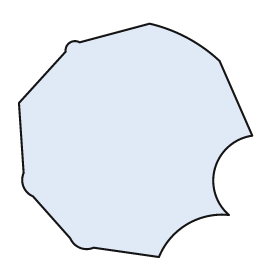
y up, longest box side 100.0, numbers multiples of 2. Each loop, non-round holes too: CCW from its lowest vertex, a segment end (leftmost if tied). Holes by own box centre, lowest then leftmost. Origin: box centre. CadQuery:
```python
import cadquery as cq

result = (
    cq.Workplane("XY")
    .moveTo(10.0, -50.0)
    .threePointArc((22.0, -36.0), (40.0, -32.0))
    .threePointArc((34.0, -12.0), (50.0, 2.0))
    .lineTo(36.0, 34.0)
    .threePointArc((22.0, 44.0), (6.0, 50.0))
    .lineTo(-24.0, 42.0)
    .threePointArc((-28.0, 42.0), (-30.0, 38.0))
    .lineTo(-50.0, 16.0)
    .lineTo(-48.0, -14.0)
    .threePointArc((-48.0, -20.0), (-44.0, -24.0))
    .lineTo(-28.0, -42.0)
    .threePointArc((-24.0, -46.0), (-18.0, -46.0))
    .close()
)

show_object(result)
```